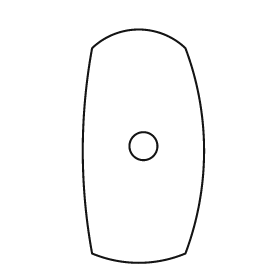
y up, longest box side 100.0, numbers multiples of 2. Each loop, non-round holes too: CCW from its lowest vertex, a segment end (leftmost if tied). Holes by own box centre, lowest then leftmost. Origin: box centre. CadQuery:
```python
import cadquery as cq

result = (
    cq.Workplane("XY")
    .moveTo(-22.0, -46.0)
    .threePointArc((-2.0, -50.0), (18.0, -46.0))
    .threePointArc((26.0, -2.0), (18.0, 42.0))
    .threePointArc((-2.0, 50.0), (-22.0, 42.0))
    .threePointArc((-26.0, -2.0), (-22.0, -46.0))
    .close()
    .moveTo(0.0, 0.0)
    .circle(6.0)
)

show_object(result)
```